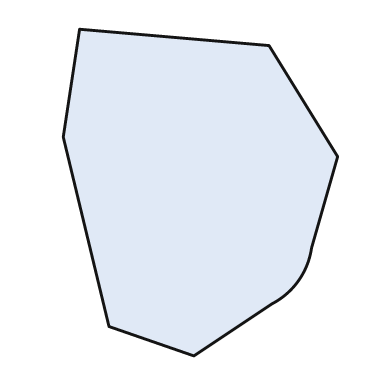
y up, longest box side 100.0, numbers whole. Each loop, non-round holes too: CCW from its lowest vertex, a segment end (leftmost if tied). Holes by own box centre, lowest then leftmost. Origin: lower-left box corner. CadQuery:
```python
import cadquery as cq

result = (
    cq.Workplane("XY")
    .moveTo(40.0, 0.0)
    .lineTo(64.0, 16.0)
    .threePointArc((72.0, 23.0), (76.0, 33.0))
    .lineTo(84.0, 61.0)
    .lineTo(63.0, 95.0)
    .lineTo(5.0, 100.0)
    .lineTo(0.0, 67.0)
    .lineTo(14.0, 9.0)
    .close()
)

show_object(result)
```